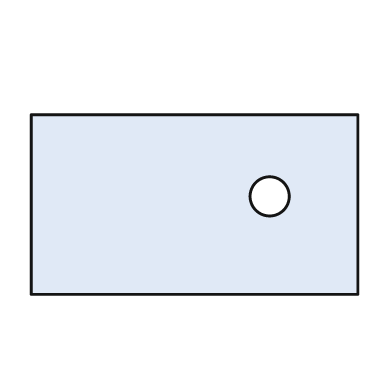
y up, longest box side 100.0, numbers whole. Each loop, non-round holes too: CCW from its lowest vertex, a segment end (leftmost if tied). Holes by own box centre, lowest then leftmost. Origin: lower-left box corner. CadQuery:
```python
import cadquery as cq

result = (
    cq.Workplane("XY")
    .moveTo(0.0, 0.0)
    .lineTo(100.0, 0.0)
    .lineTo(100.0, 55.0)
    .lineTo(0.0, 55.0)
    .close()
    .moveTo(73.0, 30.0)
    .circle(6.0)
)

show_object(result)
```